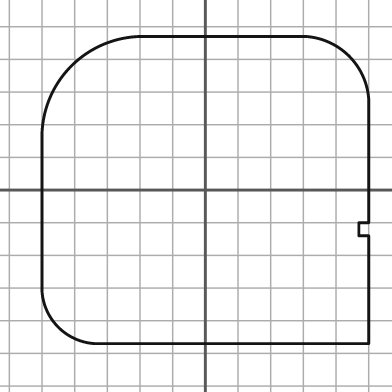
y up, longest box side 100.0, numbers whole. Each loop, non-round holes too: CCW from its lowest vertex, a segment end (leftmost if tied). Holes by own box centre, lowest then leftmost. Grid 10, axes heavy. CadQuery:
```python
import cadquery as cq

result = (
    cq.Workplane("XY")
    .moveTo(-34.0, -47.0)
    .lineTo(50.0, -47.0)
    .lineTo(50.0, -14.0)
    .lineTo(47.0, -14.0)
    .lineTo(47.0, -10.0)
    .lineTo(50.0, -10.0)
    .lineTo(50.0, 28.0)
    .threePointArc((44.0, 41.0), (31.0, 47.0))
    .lineTo(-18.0, 47.0)
    .threePointArc((-41.0, 38.0), (-50.0, 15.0))
    .lineTo(-50.0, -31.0)
    .threePointArc((-45.0, -42.0), (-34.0, -47.0))
    .close()
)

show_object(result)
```